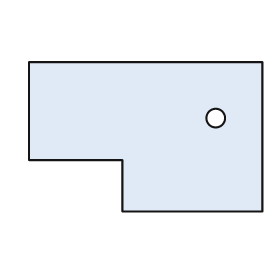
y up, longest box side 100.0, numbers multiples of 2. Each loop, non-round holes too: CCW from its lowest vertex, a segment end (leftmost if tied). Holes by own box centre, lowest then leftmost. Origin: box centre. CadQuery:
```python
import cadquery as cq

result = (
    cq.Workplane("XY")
    .moveTo(-10.0, -32.0)
    .lineTo(50.0, -32.0)
    .lineTo(50.0, 32.0)
    .lineTo(-50.0, 32.0)
    .lineTo(-50.0, -10.0)
    .lineTo(-10.0, -10.0)
    .close()
    .moveTo(30.0, 8.0)
    .circle(4.0)
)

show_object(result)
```